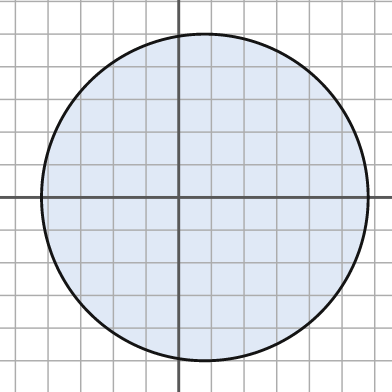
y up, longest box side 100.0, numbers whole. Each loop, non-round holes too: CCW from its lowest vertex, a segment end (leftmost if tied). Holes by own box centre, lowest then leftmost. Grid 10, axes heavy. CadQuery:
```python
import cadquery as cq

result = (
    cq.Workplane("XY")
    .moveTo(8.0, 0.0)
    .circle(50.0)
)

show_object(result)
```